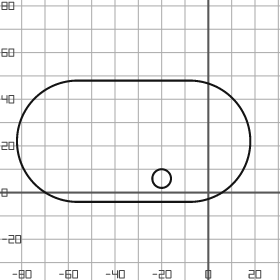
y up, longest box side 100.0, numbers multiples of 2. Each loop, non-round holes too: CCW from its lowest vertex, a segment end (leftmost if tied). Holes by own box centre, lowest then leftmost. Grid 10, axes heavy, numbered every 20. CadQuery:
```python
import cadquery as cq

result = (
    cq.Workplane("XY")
    .moveTo(-56.0, -4.0)
    .lineTo(-8.0, -4.0)
    .threePointArc((18.0, 22.0), (-8.0, 48.0))
    .lineTo(-56.0, 48.0)
    .threePointArc((-82.0, 22.0), (-56.0, -4.0))
    .close()
    .moveTo(-20.0, 6.0)
    .circle(4.0)
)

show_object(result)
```